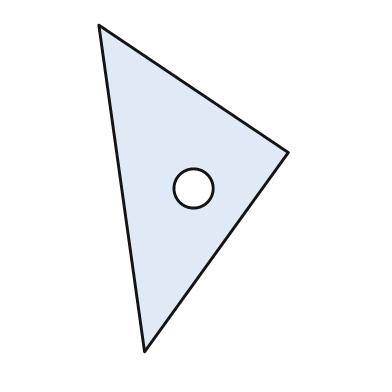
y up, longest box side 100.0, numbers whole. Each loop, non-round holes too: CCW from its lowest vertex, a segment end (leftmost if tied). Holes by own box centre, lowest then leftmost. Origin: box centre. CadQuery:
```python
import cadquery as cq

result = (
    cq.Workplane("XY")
    .moveTo(-15.0, -50.0)
    .lineTo(29.0, 11.0)
    .lineTo(-29.0, 50.0)
    .close()
    .moveTo(0.0, 0.0)
    .circle(6.0)
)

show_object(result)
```